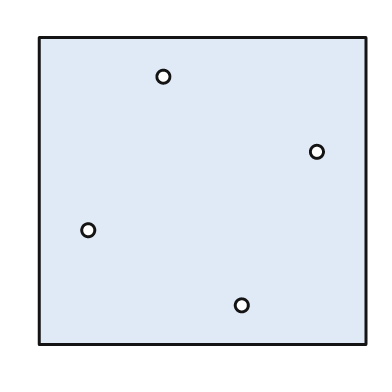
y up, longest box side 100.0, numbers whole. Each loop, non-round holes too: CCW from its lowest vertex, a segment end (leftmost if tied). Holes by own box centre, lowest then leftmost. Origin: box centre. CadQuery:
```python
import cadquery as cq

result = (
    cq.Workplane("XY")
    .moveTo(-50.0, -47.0)
    .lineTo(50.0, -47.0)
    .lineTo(50.0, 47.0)
    .lineTo(-50.0, 47.0)
    .close()
    .moveTo(12.0, -35.0)
    .circle(2.0)
    .moveTo(-35.0, -12.0)
    .circle(2.0)
    .moveTo(35.0, 12.0)
    .circle(2.0)
    .moveTo(-12.0, 35.0)
    .circle(2.0)
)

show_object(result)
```